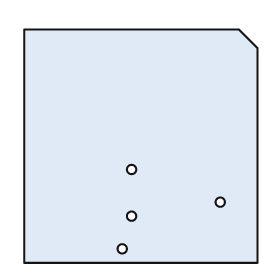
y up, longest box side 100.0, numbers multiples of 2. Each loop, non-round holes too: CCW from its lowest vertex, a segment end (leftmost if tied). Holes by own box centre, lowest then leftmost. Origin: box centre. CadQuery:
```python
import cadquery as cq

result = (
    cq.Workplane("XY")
    .moveTo(-50.0, -50.0)
    .lineTo(50.0, -50.0)
    .lineTo(50.0, 42.0)
    .lineTo(42.0, 50.0)
    .lineTo(-50.0, 50.0)
    .close()
    .moveTo(-8.0, -44.0)
    .circle(2.0)
    .moveTo(-4.0, -30.0)
    .circle(2.0)
    .moveTo(34.0, -24.0)
    .circle(2.0)
    .moveTo(-4.0, -10.0)
    .circle(2.0)
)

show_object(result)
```